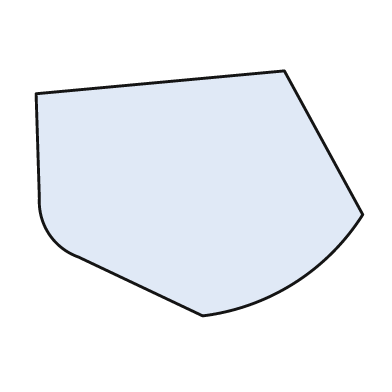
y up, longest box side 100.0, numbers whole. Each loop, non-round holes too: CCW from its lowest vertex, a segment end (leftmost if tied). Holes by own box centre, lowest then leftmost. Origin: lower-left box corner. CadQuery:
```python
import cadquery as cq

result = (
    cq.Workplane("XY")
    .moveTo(51.0, 0.0)
    .threePointArc((79.0, 10.0), (100.0, 31.0))
    .lineTo(76.0, 75.0)
    .lineTo(0.0, 68.0)
    .lineTo(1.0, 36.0)
    .threePointArc((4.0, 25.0), (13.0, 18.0))
    .close()
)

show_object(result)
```